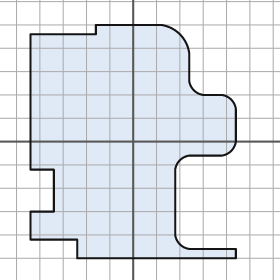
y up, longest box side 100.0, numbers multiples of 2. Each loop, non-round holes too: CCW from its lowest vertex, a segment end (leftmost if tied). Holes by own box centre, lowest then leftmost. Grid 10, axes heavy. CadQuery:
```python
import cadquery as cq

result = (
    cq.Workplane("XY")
    .moveTo(-24.0, -50.0)
    .lineTo(44.0, -50.0)
    .lineTo(44.0, -46.0)
    .lineTo(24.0, -46.0)
    .threePointArc((20.0, -44.0), (18.0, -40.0))
    .lineTo(18.0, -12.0)
    .threePointArc((20.0, -8.0), (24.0, -6.0))
    .lineTo(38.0, -6.0)
    .threePointArc((42.0, -4.0), (44.0, 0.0))
    .lineTo(44.0, 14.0)
    .threePointArc((42.0, 18.0), (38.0, 20.0))
    .lineTo(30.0, 20.0)
    .threePointArc((26.0, 22.0), (24.0, 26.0))
    .lineTo(24.0, 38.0)
    .threePointArc((20.0, 46.0), (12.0, 50.0))
    .lineTo(-16.0, 50.0)
    .lineTo(-16.0, 46.0)
    .lineTo(-44.0, 46.0)
    .lineTo(-44.0, -12.0)
    .lineTo(-34.0, -12.0)
    .lineTo(-34.0, -30.0)
    .lineTo(-44.0, -30.0)
    .lineTo(-44.0, -42.0)
    .lineTo(-24.0, -42.0)
    .close()
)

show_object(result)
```